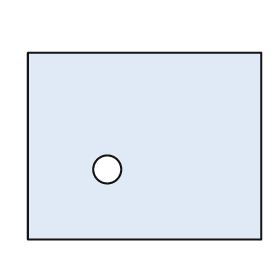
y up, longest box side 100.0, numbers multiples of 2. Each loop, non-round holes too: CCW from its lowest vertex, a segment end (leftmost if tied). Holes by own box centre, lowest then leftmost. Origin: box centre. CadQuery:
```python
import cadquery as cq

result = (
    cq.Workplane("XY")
    .moveTo(-50.0, -40.0)
    .lineTo(50.0, -40.0)
    .lineTo(50.0, 40.0)
    .lineTo(-50.0, 40.0)
    .close()
    .moveTo(-16.0, -10.0)
    .circle(6.0)
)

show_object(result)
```